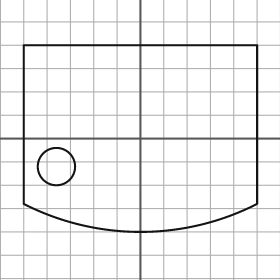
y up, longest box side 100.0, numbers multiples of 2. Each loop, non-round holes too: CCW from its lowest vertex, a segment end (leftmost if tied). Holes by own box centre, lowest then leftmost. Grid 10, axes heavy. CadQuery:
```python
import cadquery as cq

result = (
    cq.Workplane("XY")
    .moveTo(-50.0, -28.0)
    .threePointArc((0.0, -40.0), (50.0, -28.0))
    .lineTo(50.0, 40.0)
    .lineTo(-50.0, 40.0)
    .close()
    .moveTo(-36.0, -12.0)
    .circle(8.0)
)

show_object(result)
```